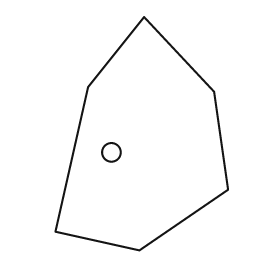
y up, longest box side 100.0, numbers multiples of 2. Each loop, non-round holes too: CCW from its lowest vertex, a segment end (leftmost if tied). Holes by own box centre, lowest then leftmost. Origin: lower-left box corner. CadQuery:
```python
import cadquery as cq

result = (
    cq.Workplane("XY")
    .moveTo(36.0, 0.0)
    .lineTo(74.0, 26.0)
    .lineTo(68.0, 68.0)
    .lineTo(38.0, 100.0)
    .lineTo(14.0, 70.0)
    .lineTo(0.0, 8.0)
    .close()
    .moveTo(24.0, 42.0)
    .circle(4.0)
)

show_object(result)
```